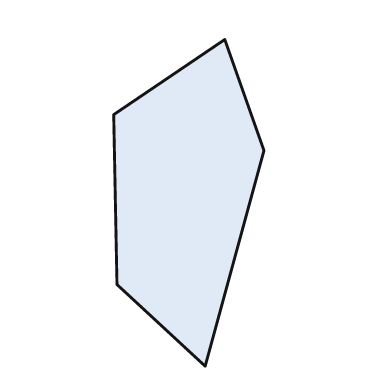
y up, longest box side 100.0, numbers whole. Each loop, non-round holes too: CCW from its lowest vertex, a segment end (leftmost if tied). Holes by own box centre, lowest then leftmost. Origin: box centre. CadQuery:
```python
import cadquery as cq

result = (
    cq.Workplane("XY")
    .moveTo(5.0, -50.0)
    .lineTo(23.0, 16.0)
    .lineTo(11.0, 50.0)
    .lineTo(-23.0, 27.0)
    .lineTo(-22.0, -25.0)
    .close()
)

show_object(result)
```